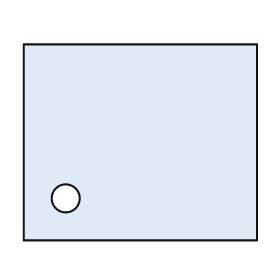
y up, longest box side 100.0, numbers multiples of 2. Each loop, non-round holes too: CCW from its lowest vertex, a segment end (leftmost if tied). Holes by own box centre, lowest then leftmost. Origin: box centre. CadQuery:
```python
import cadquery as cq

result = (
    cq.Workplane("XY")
    .moveTo(-50.0, -42.0)
    .lineTo(50.0, -42.0)
    .lineTo(50.0, 42.0)
    .lineTo(-50.0, 42.0)
    .close()
    .moveTo(-32.0, -24.0)
    .circle(6.0)
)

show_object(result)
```